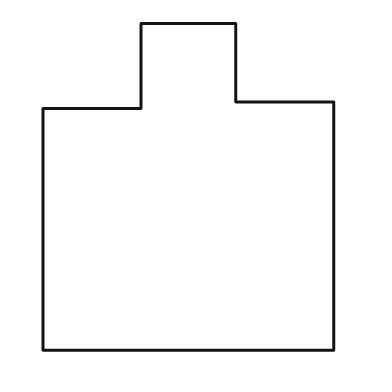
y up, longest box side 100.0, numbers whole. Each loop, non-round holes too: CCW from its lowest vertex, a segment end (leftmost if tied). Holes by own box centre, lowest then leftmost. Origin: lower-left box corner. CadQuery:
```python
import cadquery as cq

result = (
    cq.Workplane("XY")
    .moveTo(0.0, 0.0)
    .lineTo(89.0, 0.0)
    .lineTo(89.0, 76.0)
    .lineTo(59.0, 76.0)
    .lineTo(59.0, 100.0)
    .lineTo(30.0, 100.0)
    .lineTo(30.0, 74.0)
    .lineTo(0.0, 74.0)
    .close()
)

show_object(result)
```